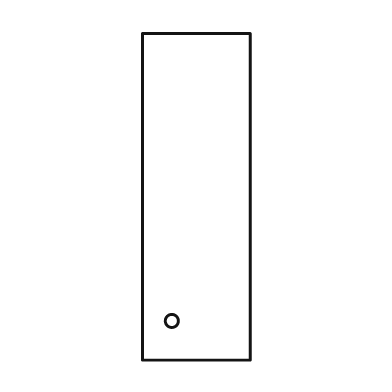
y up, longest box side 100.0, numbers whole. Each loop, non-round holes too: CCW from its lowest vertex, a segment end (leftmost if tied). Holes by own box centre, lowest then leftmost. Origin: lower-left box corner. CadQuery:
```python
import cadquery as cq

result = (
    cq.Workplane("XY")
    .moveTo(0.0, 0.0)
    .lineTo(33.0, 0.0)
    .lineTo(33.0, 100.0)
    .lineTo(0.0, 100.0)
    .close()
    .moveTo(9.0, 12.0)
    .circle(2.0)
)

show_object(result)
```